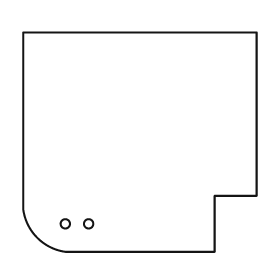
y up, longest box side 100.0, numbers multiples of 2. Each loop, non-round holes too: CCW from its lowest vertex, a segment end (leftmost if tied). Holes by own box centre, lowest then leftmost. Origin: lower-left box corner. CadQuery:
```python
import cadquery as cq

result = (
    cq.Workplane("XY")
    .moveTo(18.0, 0.0)
    .lineTo(82.0, 0.0)
    .lineTo(82.0, 24.0)
    .lineTo(100.0, 24.0)
    .lineTo(100.0, 94.0)
    .lineTo(0.0, 94.0)
    .lineTo(0.0, 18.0)
    .threePointArc((6.0, 6.0), (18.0, 0.0))
    .close()
    .moveTo(18.0, 12.0)
    .circle(2.0)
    .moveTo(28.0, 12.0)
    .circle(2.0)
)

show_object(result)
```